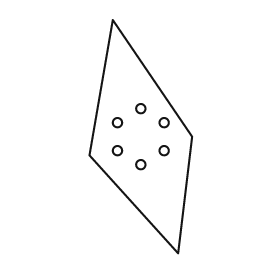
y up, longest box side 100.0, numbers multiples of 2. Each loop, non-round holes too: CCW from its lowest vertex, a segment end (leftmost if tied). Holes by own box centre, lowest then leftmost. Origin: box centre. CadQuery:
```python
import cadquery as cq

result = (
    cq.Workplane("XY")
    .moveTo(16.0, -50.0)
    .lineTo(22.0, 0.0)
    .lineTo(-12.0, 50.0)
    .lineTo(-22.0, -8.0)
    .close()
    .moveTo(0.0, -12.0)
    .circle(2.0)
    .moveTo(-10.0, -6.0)
    .circle(2.0)
    .moveTo(10.0, -6.0)
    .circle(2.0)
    .moveTo(-10.0, 6.0)
    .circle(2.0)
    .moveTo(10.0, 6.0)
    .circle(2.0)
    .moveTo(0.0, 12.0)
    .circle(2.0)
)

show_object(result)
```